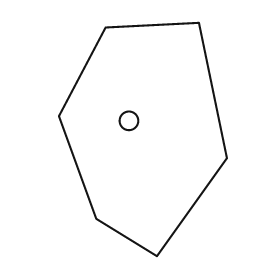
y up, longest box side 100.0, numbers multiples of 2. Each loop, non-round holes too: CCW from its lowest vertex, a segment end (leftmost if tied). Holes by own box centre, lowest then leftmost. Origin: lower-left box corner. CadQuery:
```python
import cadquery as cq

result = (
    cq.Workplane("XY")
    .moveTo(42.0, 0.0)
    .lineTo(72.0, 42.0)
    .lineTo(60.0, 100.0)
    .lineTo(20.0, 98.0)
    .lineTo(0.0, 60.0)
    .lineTo(16.0, 16.0)
    .close()
    .moveTo(30.0, 58.0)
    .circle(4.0)
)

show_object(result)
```